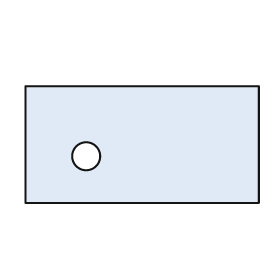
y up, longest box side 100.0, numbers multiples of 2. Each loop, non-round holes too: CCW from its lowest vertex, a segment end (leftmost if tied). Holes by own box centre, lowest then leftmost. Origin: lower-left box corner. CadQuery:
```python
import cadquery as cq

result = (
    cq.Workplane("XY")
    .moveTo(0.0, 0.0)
    .lineTo(100.0, 0.0)
    .lineTo(100.0, 50.0)
    .lineTo(0.0, 50.0)
    .close()
    .moveTo(26.0, 20.0)
    .circle(6.0)
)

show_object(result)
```